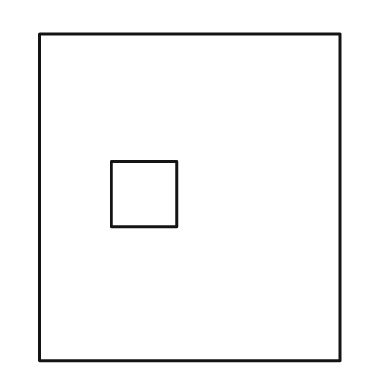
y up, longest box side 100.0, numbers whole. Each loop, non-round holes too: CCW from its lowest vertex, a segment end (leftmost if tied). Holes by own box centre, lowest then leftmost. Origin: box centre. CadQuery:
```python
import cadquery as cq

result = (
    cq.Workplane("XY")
    .moveTo(-46.0, -50.0)
    .lineTo(46.0, -50.0)
    .lineTo(46.0, 50.0)
    .lineTo(-46.0, 50.0)
    .close()
    .moveTo(-24.0, -9.0)
    .lineTo(-4.0, -9.0)
    .lineTo(-4.0, 11.0)
    .lineTo(-24.0, 11.0)
    .close()
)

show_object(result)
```